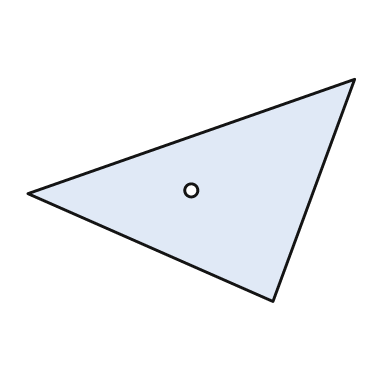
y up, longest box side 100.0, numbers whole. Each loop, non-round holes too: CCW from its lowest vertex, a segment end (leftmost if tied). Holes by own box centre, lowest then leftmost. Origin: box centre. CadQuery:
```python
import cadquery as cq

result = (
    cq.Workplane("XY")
    .moveTo(25.0, -34.0)
    .lineTo(50.0, 34.0)
    .lineTo(-50.0, -1.0)
    .close()
    .moveTo(0.0, 0.0)
    .circle(2.0)
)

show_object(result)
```